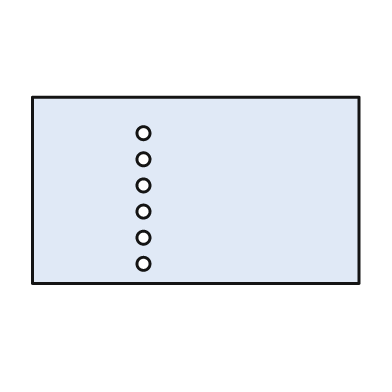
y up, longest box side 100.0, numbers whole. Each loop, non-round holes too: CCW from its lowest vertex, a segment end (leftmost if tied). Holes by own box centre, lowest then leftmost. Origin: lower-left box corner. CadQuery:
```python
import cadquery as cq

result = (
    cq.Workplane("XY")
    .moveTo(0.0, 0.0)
    .lineTo(100.0, 0.0)
    .lineTo(100.0, 57.0)
    .lineTo(0.0, 57.0)
    .close()
    .moveTo(34.0, 6.0)
    .circle(2.0)
    .moveTo(34.0, 14.0)
    .circle(2.0)
    .moveTo(34.0, 22.0)
    .circle(2.0)
    .moveTo(34.0, 30.0)
    .circle(2.0)
    .moveTo(34.0, 38.0)
    .circle(2.0)
    .moveTo(34.0, 46.0)
    .circle(2.0)
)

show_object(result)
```